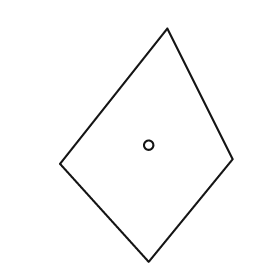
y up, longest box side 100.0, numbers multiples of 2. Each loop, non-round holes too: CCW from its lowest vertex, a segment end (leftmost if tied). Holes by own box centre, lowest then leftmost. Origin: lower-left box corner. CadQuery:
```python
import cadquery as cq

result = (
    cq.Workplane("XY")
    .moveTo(38.0, 0.0)
    .lineTo(74.0, 44.0)
    .lineTo(46.0, 100.0)
    .lineTo(0.0, 42.0)
    .close()
    .moveTo(38.0, 50.0)
    .circle(2.0)
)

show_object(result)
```